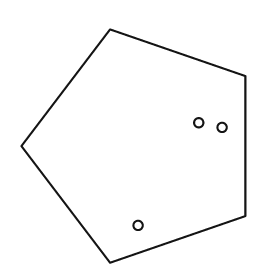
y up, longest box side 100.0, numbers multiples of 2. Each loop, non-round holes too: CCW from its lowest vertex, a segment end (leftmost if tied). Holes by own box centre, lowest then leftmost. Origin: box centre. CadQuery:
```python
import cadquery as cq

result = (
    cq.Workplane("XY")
    .moveTo(-10.0, -50.0)
    .lineTo(48.0, -30.0)
    .lineTo(48.0, 30.0)
    .lineTo(-10.0, 50.0)
    .lineTo(-48.0, 0.0)
    .close()
    .moveTo(2.0, -34.0)
    .circle(2.0)
    .moveTo(38.0, 8.0)
    .circle(2.0)
    .moveTo(28.0, 10.0)
    .circle(2.0)
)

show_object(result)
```